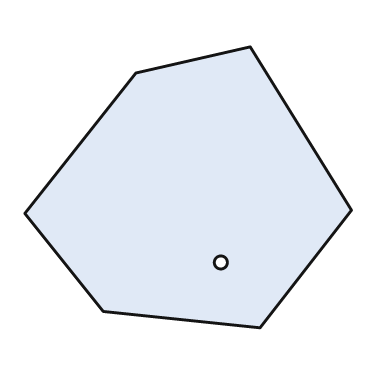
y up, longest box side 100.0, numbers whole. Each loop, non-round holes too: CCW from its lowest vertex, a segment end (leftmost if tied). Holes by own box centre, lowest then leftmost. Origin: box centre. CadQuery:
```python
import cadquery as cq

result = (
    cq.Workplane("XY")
    .moveTo(22.0, -43.0)
    .lineTo(50.0, -7.0)
    .lineTo(19.0, 43.0)
    .lineTo(-16.0, 35.0)
    .lineTo(-50.0, -8.0)
    .lineTo(-26.0, -38.0)
    .close()
    .moveTo(10.0, -23.0)
    .circle(2.0)
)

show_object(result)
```